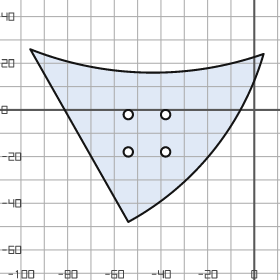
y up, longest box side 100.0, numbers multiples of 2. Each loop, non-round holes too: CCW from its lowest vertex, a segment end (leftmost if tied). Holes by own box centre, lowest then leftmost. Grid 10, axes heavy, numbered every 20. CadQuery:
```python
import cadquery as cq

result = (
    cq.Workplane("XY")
    .moveTo(-54.0, -48.0)
    .threePointArc((-18.0, -18.0), (4.0, 24.0))
    .threePointArc((-46.0, 16.0), (-96.0, 26.0))
    .close()
    .moveTo(-54.0, -18.0)
    .circle(2.0)
    .moveTo(-38.0, -18.0)
    .circle(2.0)
    .moveTo(-54.0, -2.0)
    .circle(2.0)
    .moveTo(-38.0, -2.0)
    .circle(2.0)
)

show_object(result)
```